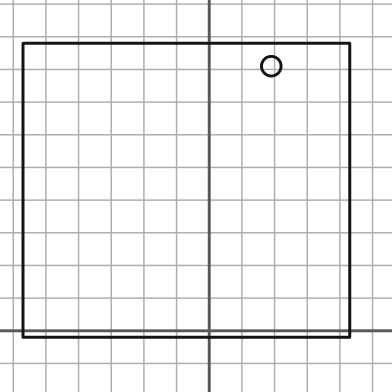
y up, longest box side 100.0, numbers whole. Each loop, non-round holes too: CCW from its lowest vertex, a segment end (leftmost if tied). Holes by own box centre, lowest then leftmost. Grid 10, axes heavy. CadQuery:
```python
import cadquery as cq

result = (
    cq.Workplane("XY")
    .moveTo(-57.0, -2.0)
    .lineTo(43.0, -2.0)
    .lineTo(43.0, 88.0)
    .lineTo(-57.0, 88.0)
    .close()
    .moveTo(19.0, 81.0)
    .circle(3.0)
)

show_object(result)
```